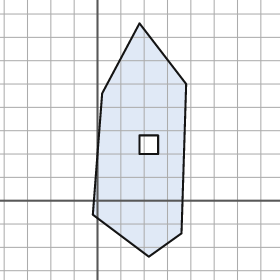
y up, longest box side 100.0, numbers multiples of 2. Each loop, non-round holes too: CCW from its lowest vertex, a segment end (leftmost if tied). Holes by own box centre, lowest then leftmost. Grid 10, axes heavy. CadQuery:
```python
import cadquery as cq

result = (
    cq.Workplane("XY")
    .moveTo(22.0, -24.0)
    .lineTo(36.0, -14.0)
    .lineTo(38.0, 50.0)
    .lineTo(18.0, 76.0)
    .lineTo(2.0, 46.0)
    .lineTo(-2.0, -6.0)
    .close()
    .moveTo(18.0, 20.0)
    .lineTo(26.0, 20.0)
    .lineTo(26.0, 28.0)
    .lineTo(18.0, 28.0)
    .close()
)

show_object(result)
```